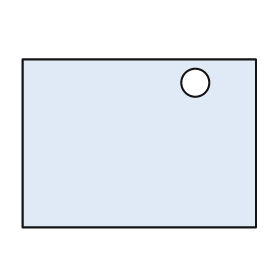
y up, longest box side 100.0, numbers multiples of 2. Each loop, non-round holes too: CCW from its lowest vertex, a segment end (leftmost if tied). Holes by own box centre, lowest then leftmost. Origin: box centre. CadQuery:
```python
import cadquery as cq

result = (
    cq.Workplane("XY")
    .moveTo(-50.0, -36.0)
    .lineTo(50.0, -36.0)
    .lineTo(50.0, 36.0)
    .lineTo(-50.0, 36.0)
    .close()
    .moveTo(24.0, 26.0)
    .circle(6.0)
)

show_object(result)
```